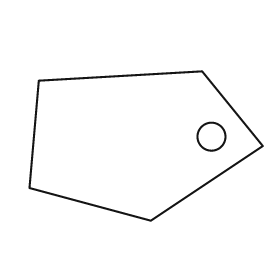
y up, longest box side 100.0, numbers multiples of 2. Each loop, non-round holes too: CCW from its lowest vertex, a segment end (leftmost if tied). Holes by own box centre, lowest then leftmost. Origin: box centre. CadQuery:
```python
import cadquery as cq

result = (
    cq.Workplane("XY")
    .moveTo(2.0, -32.0)
    .lineTo(50.0, 0.0)
    .lineTo(24.0, 32.0)
    .lineTo(-46.0, 28.0)
    .lineTo(-50.0, -18.0)
    .close()
    .moveTo(28.0, 4.0)
    .circle(6.0)
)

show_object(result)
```